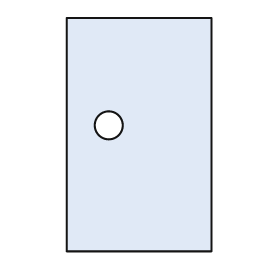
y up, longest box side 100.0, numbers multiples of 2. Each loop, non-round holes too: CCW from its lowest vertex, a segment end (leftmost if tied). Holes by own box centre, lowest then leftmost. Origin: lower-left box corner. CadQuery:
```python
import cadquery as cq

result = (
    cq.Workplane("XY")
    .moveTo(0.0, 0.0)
    .lineTo(62.0, 0.0)
    .lineTo(62.0, 100.0)
    .lineTo(0.0, 100.0)
    .close()
    .moveTo(18.0, 54.0)
    .circle(6.0)
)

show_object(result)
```